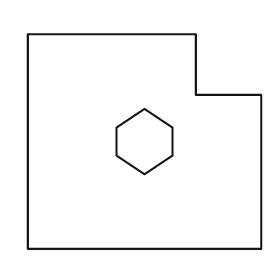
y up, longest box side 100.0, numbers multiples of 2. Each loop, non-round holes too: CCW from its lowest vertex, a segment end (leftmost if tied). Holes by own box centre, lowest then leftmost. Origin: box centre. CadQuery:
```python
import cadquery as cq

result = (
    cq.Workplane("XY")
    .moveTo(-50.0, -46.0)
    .lineTo(50.0, -46.0)
    .lineTo(50.0, 20.0)
    .lineTo(22.0, 20.0)
    .lineTo(22.0, 46.0)
    .lineTo(-50.0, 46.0)
    .close()
    .moveTo(0.0, -14.0)
    .lineTo(12.0, -6.0)
    .lineTo(12.0, 6.0)
    .lineTo(0.0, 14.0)
    .lineTo(-12.0, 6.0)
    .lineTo(-12.0, -6.0)
    .close()
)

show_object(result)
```